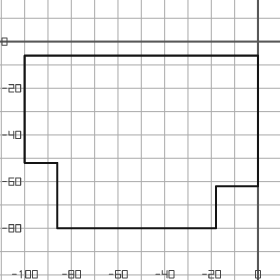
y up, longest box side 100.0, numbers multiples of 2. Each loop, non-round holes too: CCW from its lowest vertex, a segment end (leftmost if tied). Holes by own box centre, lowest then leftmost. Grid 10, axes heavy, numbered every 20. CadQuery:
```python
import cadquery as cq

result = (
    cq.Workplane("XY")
    .moveTo(-86.0, -80.0)
    .lineTo(-18.0, -80.0)
    .lineTo(-18.0, -62.0)
    .lineTo(0.0, -62.0)
    .lineTo(0.0, -6.0)
    .lineTo(-100.0, -6.0)
    .lineTo(-100.0, -52.0)
    .lineTo(-86.0, -52.0)
    .close()
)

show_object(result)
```